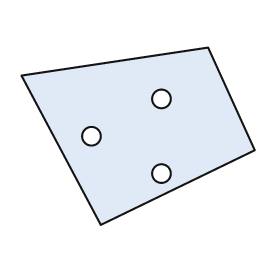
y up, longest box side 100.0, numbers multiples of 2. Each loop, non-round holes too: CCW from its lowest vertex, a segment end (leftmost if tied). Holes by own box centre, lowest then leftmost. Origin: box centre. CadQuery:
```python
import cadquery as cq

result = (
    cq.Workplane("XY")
    .moveTo(-16.0, -38.0)
    .lineTo(50.0, -6.0)
    .lineTo(30.0, 38.0)
    .lineTo(-50.0, 26.0)
    .close()
    .moveTo(10.0, -16.0)
    .circle(4.0)
    .moveTo(-20.0, 0.0)
    .circle(4.0)
    .moveTo(10.0, 16.0)
    .circle(4.0)
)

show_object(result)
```